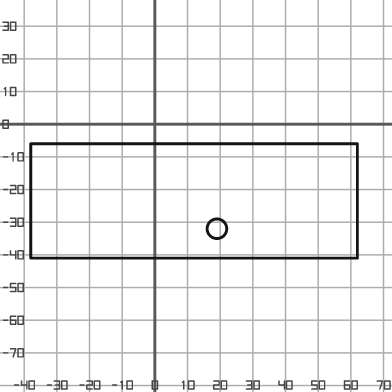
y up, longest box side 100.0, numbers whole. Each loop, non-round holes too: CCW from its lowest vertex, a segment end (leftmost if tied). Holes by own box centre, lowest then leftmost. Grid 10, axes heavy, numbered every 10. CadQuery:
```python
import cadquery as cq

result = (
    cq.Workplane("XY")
    .moveTo(-38.0, -41.0)
    .lineTo(62.0, -41.0)
    .lineTo(62.0, -6.0)
    .lineTo(-38.0, -6.0)
    .close()
    .moveTo(19.0, -32.0)
    .circle(3.0)
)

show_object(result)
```